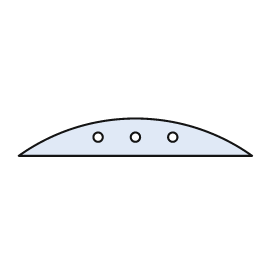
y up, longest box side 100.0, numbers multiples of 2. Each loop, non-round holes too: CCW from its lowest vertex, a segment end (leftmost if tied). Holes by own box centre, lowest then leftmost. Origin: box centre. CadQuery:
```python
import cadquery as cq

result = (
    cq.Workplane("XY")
    .moveTo(-50.0, -8.0)
    .lineTo(50.0, -8.0)
    .threePointArc((0.0, 8.0), (-50.0, -8.0))
    .close()
    .moveTo(-16.0, 0.0)
    .circle(2.0)
    .moveTo(0.0, 0.0)
    .circle(2.0)
    .moveTo(16.0, 0.0)
    .circle(2.0)
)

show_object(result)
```